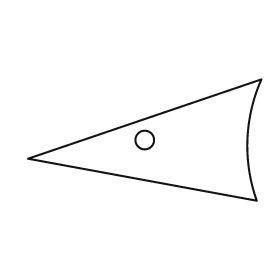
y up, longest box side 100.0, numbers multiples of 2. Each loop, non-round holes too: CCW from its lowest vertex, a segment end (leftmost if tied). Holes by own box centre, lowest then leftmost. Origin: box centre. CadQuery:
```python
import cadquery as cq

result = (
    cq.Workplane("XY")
    .moveTo(48.0, -26.0)
    .threePointArc((44.0, 0.0), (50.0, 26.0))
    .lineTo(-50.0, -8.0)
    .close()
    .moveTo(0.0, 0.0)
    .circle(4.0)
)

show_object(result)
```